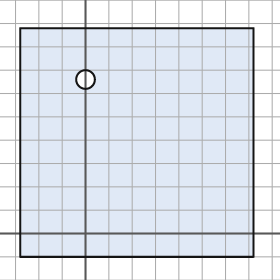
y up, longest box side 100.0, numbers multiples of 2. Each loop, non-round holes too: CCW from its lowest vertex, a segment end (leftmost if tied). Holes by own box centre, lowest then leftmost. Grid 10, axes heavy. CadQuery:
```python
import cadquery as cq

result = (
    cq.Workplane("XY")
    .moveTo(-28.0, -10.0)
    .lineTo(72.0, -10.0)
    .lineTo(72.0, 88.0)
    .lineTo(-28.0, 88.0)
    .close()
    .moveTo(0.0, 66.0)
    .circle(4.0)
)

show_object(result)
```